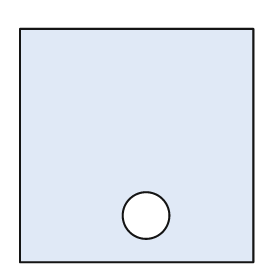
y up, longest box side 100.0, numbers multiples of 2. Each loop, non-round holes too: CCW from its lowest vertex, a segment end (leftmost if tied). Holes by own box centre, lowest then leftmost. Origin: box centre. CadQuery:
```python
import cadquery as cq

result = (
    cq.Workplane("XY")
    .moveTo(-50.0, -50.0)
    .lineTo(50.0, -50.0)
    .lineTo(50.0, 50.0)
    .lineTo(-50.0, 50.0)
    .close()
    .moveTo(4.0, -30.0)
    .circle(10.0)
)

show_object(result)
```